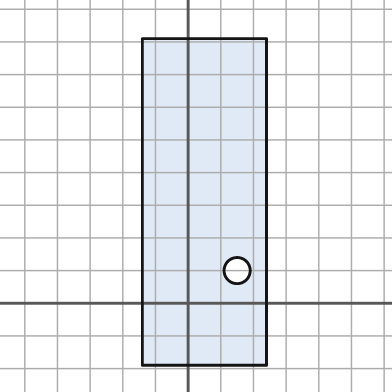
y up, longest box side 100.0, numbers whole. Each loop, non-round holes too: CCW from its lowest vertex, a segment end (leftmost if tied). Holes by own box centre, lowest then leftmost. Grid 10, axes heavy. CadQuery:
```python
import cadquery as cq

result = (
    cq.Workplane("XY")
    .moveTo(-14.0, -19.0)
    .lineTo(24.0, -19.0)
    .lineTo(24.0, 81.0)
    .lineTo(-14.0, 81.0)
    .close()
    .moveTo(15.0, 10.0)
    .circle(4.0)
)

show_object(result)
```